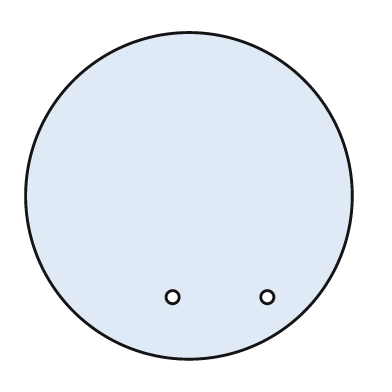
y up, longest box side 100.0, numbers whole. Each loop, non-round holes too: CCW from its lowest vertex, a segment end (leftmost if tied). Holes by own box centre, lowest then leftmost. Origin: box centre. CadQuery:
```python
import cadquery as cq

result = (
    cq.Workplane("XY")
    .moveTo(0.0, 0.0)
    .circle(50.0)
    .moveTo(-5.0, -31.0)
    .circle(2.0)
    .moveTo(24.0, -31.0)
    .circle(2.0)
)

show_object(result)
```